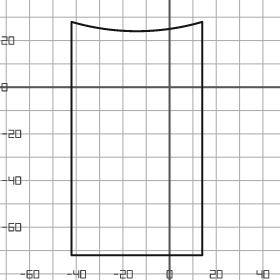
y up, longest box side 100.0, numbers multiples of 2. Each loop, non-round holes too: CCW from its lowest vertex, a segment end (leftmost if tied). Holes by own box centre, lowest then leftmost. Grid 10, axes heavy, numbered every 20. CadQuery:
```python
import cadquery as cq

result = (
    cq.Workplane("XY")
    .moveTo(-42.0, -72.0)
    .lineTo(14.0, -72.0)
    .lineTo(14.0, 28.0)
    .threePointArc((-14.0, 24.0), (-42.0, 28.0))
    .close()
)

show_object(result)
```